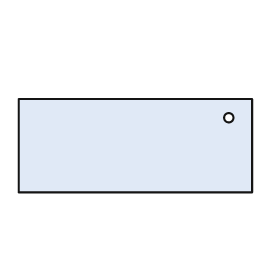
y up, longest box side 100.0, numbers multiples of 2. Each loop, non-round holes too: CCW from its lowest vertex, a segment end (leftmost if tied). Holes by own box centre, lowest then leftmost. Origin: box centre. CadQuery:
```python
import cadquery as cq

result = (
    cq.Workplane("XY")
    .moveTo(-50.0, -20.0)
    .lineTo(50.0, -20.0)
    .lineTo(50.0, 20.0)
    .lineTo(-50.0, 20.0)
    .close()
    .moveTo(40.0, 12.0)
    .circle(2.0)
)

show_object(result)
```